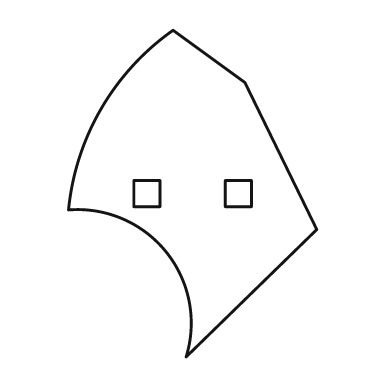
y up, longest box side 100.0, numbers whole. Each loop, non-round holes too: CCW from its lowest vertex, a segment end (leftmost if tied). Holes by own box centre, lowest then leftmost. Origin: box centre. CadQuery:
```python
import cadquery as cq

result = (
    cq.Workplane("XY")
    .moveTo(-2.0, -50.0)
    .lineTo(38.0, -11.0)
    .lineTo(16.0, 34.0)
    .lineTo(-6.0, 50.0)
    .threePointArc((-28.0, 26.0), (-38.0, -5.0))
    .threePointArc((-8.0, -18.0), (-2.0, -50.0))
    .close()
    .moveTo(-18.0, -4.0)
    .lineTo(-10.0, -4.0)
    .lineTo(-10.0, 4.0)
    .lineTo(-18.0, 4.0)
    .close()
    .moveTo(10.0, -4.0)
    .lineTo(18.0, -4.0)
    .lineTo(18.0, 4.0)
    .lineTo(10.0, 4.0)
    .close()
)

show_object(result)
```